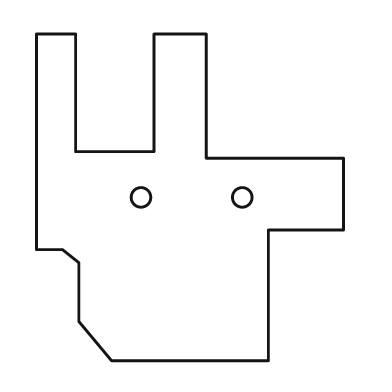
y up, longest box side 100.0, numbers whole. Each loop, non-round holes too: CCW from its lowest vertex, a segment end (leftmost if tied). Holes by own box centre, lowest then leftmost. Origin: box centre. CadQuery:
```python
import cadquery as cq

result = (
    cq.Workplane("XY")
    .moveTo(-24.0, -50.0)
    .lineTo(24.0, -50.0)
    .lineTo(24.0, -10.0)
    .lineTo(47.0, -10.0)
    .lineTo(47.0, 12.0)
    .lineTo(5.0, 12.0)
    .lineTo(5.0, 50.0)
    .lineTo(-11.0, 50.0)
    .lineTo(-11.0, 14.0)
    .lineTo(-35.0, 14.0)
    .lineTo(-35.0, 50.0)
    .lineTo(-47.0, 50.0)
    .lineTo(-47.0, -16.0)
    .lineTo(-39.0, -16.0)
    .lineTo(-34.0, -20.0)
    .lineTo(-34.0, -38.0)
    .close()
    .moveTo(-15.0, 0.0)
    .circle(3.0)
    .moveTo(16.0, 0.0)
    .circle(3.0)
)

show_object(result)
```